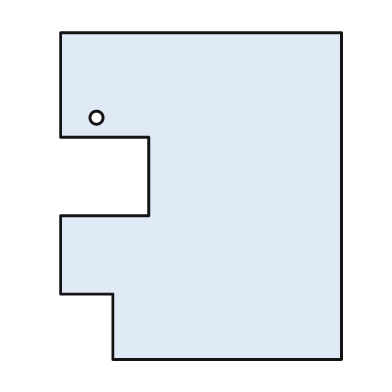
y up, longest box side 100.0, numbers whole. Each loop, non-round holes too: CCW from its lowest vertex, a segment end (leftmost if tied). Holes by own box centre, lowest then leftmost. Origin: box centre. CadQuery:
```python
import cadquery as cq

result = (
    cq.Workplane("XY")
    .moveTo(-27.0, -50.0)
    .lineTo(43.0, -50.0)
    .lineTo(43.0, 50.0)
    .lineTo(-43.0, 50.0)
    .lineTo(-43.0, 18.0)
    .lineTo(-16.0, 18.0)
    .lineTo(-16.0, -6.0)
    .lineTo(-43.0, -6.0)
    .lineTo(-43.0, -30.0)
    .lineTo(-27.0, -30.0)
    .close()
    .moveTo(-32.0, 24.0)
    .circle(2.0)
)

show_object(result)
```